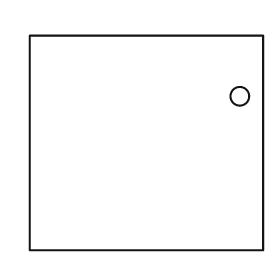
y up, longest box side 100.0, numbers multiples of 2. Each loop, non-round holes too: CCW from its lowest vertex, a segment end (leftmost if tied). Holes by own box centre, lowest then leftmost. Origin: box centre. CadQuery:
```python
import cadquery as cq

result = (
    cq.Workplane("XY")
    .moveTo(-50.0, -46.0)
    .lineTo(50.0, -46.0)
    .lineTo(50.0, 46.0)
    .lineTo(-50.0, 46.0)
    .close()
    .moveTo(40.0, 20.0)
    .circle(4.0)
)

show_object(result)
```